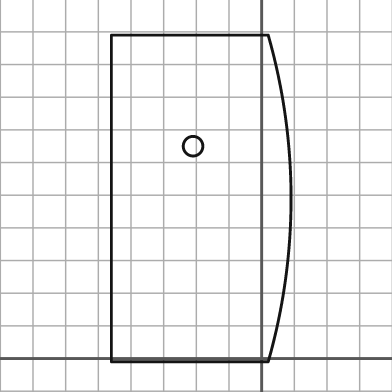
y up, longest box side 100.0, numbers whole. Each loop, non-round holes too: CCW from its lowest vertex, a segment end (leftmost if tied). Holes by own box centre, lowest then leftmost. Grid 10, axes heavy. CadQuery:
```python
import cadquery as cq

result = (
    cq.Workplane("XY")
    .moveTo(-46.0, -1.0)
    .lineTo(2.0, -1.0)
    .threePointArc((9.0, 49.0), (2.0, 99.0))
    .lineTo(-46.0, 99.0)
    .close()
    .moveTo(-21.0, 65.0)
    .circle(3.0)
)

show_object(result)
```